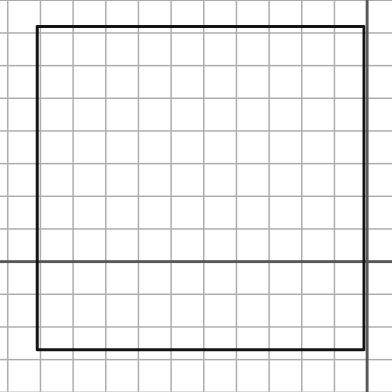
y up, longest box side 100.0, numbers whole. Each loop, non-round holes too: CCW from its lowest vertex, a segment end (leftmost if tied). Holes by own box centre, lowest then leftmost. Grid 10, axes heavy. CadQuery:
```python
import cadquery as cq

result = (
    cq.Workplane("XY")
    .moveTo(-101.0, -27.0)
    .lineTo(-1.0, -27.0)
    .lineTo(-1.0, 72.0)
    .lineTo(-101.0, 72.0)
    .close()
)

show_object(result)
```